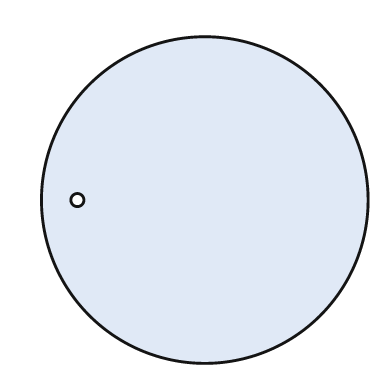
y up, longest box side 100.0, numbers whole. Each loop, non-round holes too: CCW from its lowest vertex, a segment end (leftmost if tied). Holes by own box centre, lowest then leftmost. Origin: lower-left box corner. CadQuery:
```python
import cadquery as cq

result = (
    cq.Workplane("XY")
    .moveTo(50.0, 50.0)
    .circle(50.0)
    .moveTo(11.0, 50.0)
    .circle(2.0)
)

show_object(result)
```